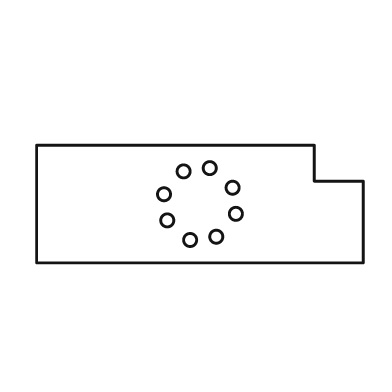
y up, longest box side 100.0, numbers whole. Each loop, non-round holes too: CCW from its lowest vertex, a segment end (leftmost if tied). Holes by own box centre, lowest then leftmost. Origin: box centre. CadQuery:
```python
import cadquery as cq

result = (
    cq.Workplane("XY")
    .moveTo(-50.0, -18.0)
    .lineTo(50.0, -18.0)
    .lineTo(50.0, 7.0)
    .lineTo(35.0, 7.0)
    .lineTo(35.0, 18.0)
    .lineTo(-50.0, 18.0)
    .close()
    .moveTo(-3.0, -11.0)
    .circle(2.0)
    .moveTo(5.0, -10.0)
    .circle(2.0)
    .moveTo(-10.0, -5.0)
    .circle(2.0)
    .moveTo(11.0, -3.0)
    .circle(2.0)
    .moveTo(-11.0, 3.0)
    .circle(2.0)
    .moveTo(10.0, 5.0)
    .circle(2.0)
    .moveTo(-5.0, 10.0)
    .circle(2.0)
    .moveTo(3.0, 11.0)
    .circle(2.0)
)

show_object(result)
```